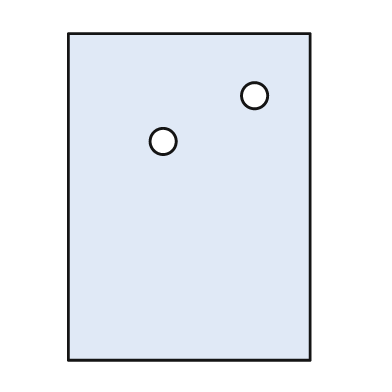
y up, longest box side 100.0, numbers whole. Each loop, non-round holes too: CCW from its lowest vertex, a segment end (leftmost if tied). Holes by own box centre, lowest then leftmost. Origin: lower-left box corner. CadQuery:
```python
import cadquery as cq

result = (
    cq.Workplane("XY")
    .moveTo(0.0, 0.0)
    .lineTo(74.0, 0.0)
    .lineTo(74.0, 100.0)
    .lineTo(0.0, 100.0)
    .close()
    .moveTo(29.0, 67.0)
    .circle(4.0)
    .moveTo(57.0, 81.0)
    .circle(4.0)
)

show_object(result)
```